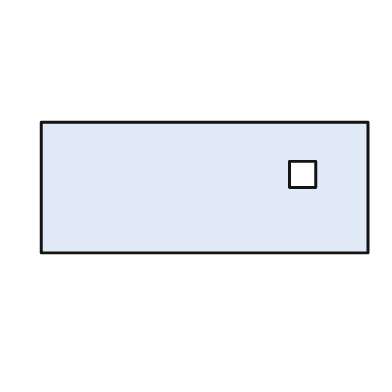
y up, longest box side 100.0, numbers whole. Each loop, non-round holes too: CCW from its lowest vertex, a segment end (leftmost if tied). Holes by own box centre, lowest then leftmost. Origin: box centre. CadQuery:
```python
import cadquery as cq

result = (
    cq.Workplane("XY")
    .moveTo(-50.0, -20.0)
    .lineTo(50.0, -20.0)
    .lineTo(50.0, 20.0)
    .lineTo(-50.0, 20.0)
    .close()
    .moveTo(26.0, 0.0)
    .lineTo(34.0, 0.0)
    .lineTo(34.0, 8.0)
    .lineTo(26.0, 8.0)
    .close()
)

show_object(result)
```